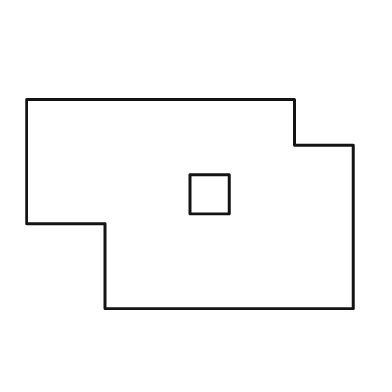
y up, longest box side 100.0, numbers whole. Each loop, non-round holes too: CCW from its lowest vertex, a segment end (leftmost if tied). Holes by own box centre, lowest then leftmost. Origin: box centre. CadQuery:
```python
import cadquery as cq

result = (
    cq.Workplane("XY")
    .moveTo(-26.0, -32.0)
    .lineTo(50.0, -32.0)
    .lineTo(50.0, 18.0)
    .lineTo(32.0, 18.0)
    .lineTo(32.0, 32.0)
    .lineTo(-50.0, 32.0)
    .lineTo(-50.0, -6.0)
    .lineTo(-26.0, -6.0)
    .close()
    .moveTo(0.0, -3.0)
    .lineTo(12.0, -3.0)
    .lineTo(12.0, 9.0)
    .lineTo(0.0, 9.0)
    .close()
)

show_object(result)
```